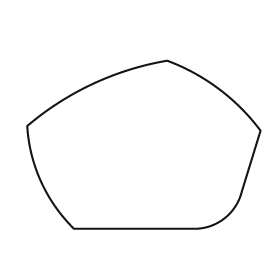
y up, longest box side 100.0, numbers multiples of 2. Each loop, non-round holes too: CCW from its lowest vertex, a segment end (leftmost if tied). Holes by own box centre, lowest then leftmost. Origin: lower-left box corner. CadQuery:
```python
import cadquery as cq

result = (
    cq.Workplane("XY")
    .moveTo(20.0, 0.0)
    .lineTo(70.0, 0.0)
    .threePointArc((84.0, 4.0), (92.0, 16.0))
    .lineTo(100.0, 42.0)
    .threePointArc((82.0, 60.0), (60.0, 72.0))
    .threePointArc((28.0, 62.0), (0.0, 44.0))
    .threePointArc((6.0, 20.0), (20.0, 0.0))
    .close()
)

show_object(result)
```